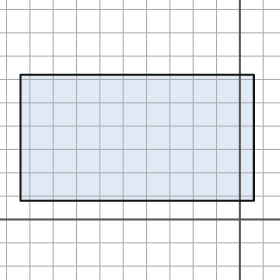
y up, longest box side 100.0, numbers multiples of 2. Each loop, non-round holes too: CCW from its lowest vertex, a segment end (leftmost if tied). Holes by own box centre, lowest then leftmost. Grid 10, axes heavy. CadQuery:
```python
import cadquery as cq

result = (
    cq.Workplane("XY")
    .moveTo(-94.0, 8.0)
    .lineTo(6.0, 8.0)
    .lineTo(6.0, 62.0)
    .lineTo(-94.0, 62.0)
    .close()
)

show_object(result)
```